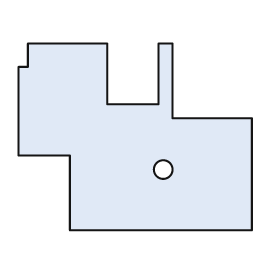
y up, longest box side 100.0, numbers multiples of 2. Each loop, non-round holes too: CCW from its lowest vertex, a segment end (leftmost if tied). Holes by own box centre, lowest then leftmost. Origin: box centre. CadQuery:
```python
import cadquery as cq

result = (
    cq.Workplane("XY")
    .moveTo(-28.0, -40.0)
    .lineTo(50.0, -40.0)
    .lineTo(50.0, 8.0)
    .lineTo(16.0, 8.0)
    .lineTo(16.0, 40.0)
    .lineTo(10.0, 40.0)
    .lineTo(10.0, 14.0)
    .lineTo(-12.0, 14.0)
    .lineTo(-12.0, 40.0)
    .lineTo(-46.0, 40.0)
    .lineTo(-46.0, 30.0)
    .lineTo(-50.0, 30.0)
    .lineTo(-50.0, -8.0)
    .lineTo(-28.0, -8.0)
    .close()
    .moveTo(12.0, -14.0)
    .circle(4.0)
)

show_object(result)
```